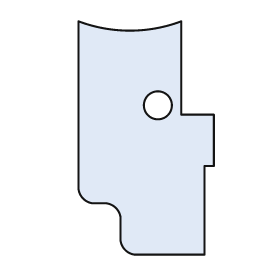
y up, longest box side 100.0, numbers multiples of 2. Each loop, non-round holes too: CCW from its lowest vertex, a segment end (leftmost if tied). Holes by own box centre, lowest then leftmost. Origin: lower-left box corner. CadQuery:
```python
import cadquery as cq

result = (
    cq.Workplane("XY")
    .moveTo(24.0, 0.0)
    .lineTo(54.0, 0.0)
    .lineTo(54.0, 38.0)
    .lineTo(58.0, 38.0)
    .lineTo(58.0, 60.0)
    .lineTo(44.0, 60.0)
    .lineTo(44.0, 100.0)
    .threePointArc((22.0, 96.0), (0.0, 100.0))
    .lineTo(0.0, 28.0)
    .threePointArc((2.0, 24.0), (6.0, 22.0))
    .lineTo(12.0, 22.0)
    .threePointArc((16.0, 20.0), (18.0, 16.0))
    .lineTo(18.0, 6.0)
    .threePointArc((20.0, 2.0), (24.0, 0.0))
    .close()
    .moveTo(34.0, 64.0)
    .circle(6.0)
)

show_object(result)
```